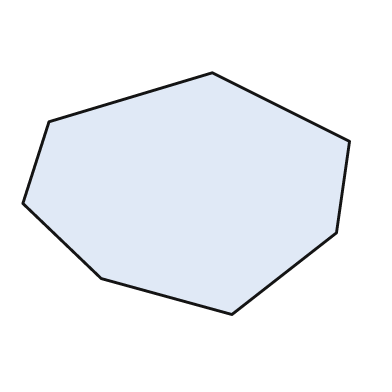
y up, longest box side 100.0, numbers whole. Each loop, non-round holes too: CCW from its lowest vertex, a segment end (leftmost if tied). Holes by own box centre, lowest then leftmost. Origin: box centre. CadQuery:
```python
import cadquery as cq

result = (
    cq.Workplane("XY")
    .moveTo(14.0, -37.0)
    .lineTo(46.0, -12.0)
    .lineTo(50.0, 16.0)
    .lineTo(8.0, 37.0)
    .lineTo(-42.0, 22.0)
    .lineTo(-50.0, -3.0)
    .lineTo(-26.0, -26.0)
    .close()
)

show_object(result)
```